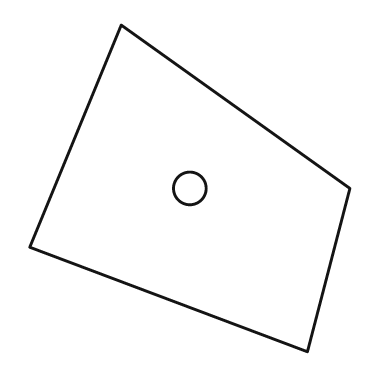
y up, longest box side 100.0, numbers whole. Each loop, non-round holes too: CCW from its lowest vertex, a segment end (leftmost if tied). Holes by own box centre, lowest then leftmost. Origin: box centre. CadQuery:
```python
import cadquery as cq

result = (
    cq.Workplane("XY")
    .moveTo(36.0, -50.0)
    .lineTo(49.0, 0.0)
    .lineTo(-21.0, 50.0)
    .lineTo(-49.0, -18.0)
    .close()
    .moveTo(0.0, 0.0)
    .circle(5.0)
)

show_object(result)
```